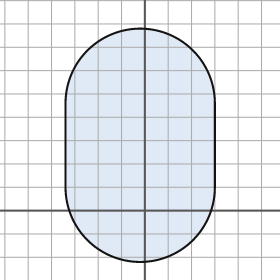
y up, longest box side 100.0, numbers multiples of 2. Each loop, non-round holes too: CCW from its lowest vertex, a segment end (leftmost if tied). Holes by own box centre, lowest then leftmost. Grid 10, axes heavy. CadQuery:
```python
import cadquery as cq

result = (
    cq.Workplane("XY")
    .moveTo(-34.0, 10.0)
    .threePointArc((-2.0, -22.0), (30.0, 10.0))
    .lineTo(30.0, 46.0)
    .threePointArc((-2.0, 78.0), (-34.0, 46.0))
    .close()
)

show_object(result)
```